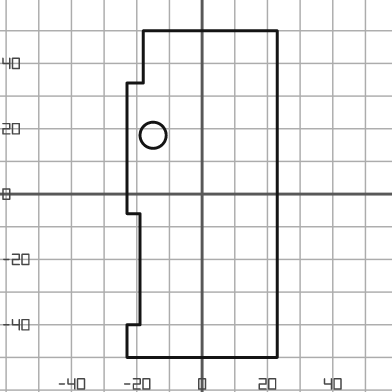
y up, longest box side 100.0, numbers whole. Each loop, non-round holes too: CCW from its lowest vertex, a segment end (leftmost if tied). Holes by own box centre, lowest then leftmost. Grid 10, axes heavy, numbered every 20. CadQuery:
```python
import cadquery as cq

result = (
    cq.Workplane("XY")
    .moveTo(-23.0, -50.0)
    .lineTo(23.0, -50.0)
    .lineTo(23.0, 50.0)
    .lineTo(-18.0, 50.0)
    .lineTo(-18.0, 34.0)
    .lineTo(-23.0, 34.0)
    .lineTo(-23.0, -6.0)
    .lineTo(-19.0, -6.0)
    .lineTo(-19.0, -40.0)
    .lineTo(-23.0, -40.0)
    .close()
    .moveTo(-15.0, 18.0)
    .circle(4.0)
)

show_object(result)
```